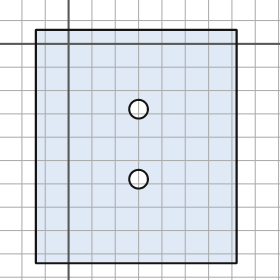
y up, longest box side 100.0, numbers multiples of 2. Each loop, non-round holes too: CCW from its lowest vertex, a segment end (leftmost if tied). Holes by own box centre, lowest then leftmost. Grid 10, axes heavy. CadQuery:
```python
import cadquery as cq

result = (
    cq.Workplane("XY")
    .moveTo(-14.0, -94.0)
    .lineTo(72.0, -94.0)
    .lineTo(72.0, 6.0)
    .lineTo(-14.0, 6.0)
    .close()
    .moveTo(30.0, -58.0)
    .circle(4.0)
    .moveTo(30.0, -28.0)
    .circle(4.0)
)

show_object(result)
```